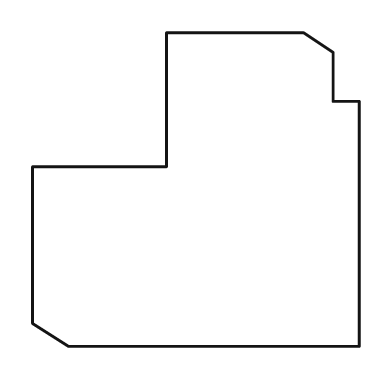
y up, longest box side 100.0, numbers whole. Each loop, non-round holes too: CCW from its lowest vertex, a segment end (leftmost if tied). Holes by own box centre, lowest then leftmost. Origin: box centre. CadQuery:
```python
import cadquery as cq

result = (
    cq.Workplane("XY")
    .moveTo(-39.0, -48.0)
    .lineTo(50.0, -48.0)
    .lineTo(50.0, 27.0)
    .lineTo(42.0, 27.0)
    .lineTo(42.0, 42.0)
    .lineTo(33.0, 48.0)
    .lineTo(-9.0, 48.0)
    .lineTo(-9.0, 7.0)
    .lineTo(-50.0, 7.0)
    .lineTo(-50.0, -41.0)
    .close()
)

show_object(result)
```